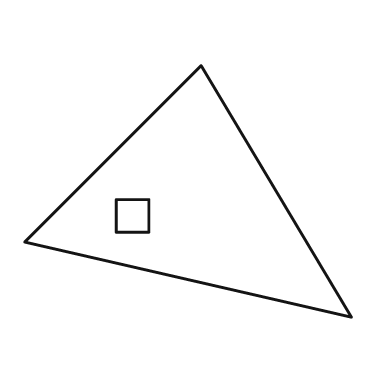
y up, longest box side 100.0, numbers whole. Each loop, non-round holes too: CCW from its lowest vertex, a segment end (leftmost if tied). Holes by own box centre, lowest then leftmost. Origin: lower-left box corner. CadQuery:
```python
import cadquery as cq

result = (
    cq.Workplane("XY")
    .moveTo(100.0, 0.0)
    .lineTo(54.0, 77.0)
    .lineTo(0.0, 23.0)
    .close()
    .moveTo(28.0, 26.0)
    .lineTo(38.0, 26.0)
    .lineTo(38.0, 36.0)
    .lineTo(28.0, 36.0)
    .close()
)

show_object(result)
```